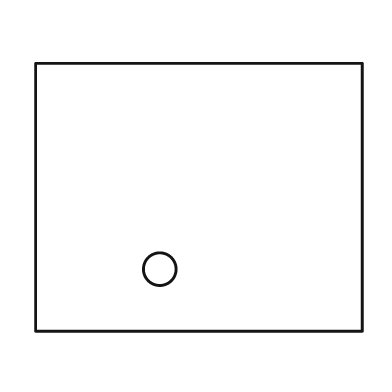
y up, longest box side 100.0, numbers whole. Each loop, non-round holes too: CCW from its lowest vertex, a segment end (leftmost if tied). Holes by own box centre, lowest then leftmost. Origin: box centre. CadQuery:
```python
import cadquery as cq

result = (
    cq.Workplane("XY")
    .moveTo(-50.0, -41.0)
    .lineTo(50.0, -41.0)
    .lineTo(50.0, 41.0)
    .lineTo(-50.0, 41.0)
    .close()
    .moveTo(-12.0, -22.0)
    .circle(5.0)
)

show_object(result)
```